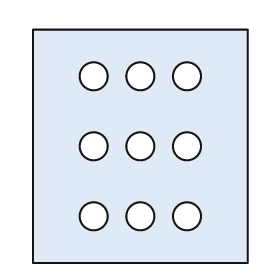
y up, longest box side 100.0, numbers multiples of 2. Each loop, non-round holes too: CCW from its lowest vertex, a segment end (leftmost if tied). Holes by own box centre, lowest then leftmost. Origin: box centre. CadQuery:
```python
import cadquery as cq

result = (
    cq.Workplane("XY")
    .moveTo(-46.0, -50.0)
    .lineTo(46.0, -50.0)
    .lineTo(46.0, 50.0)
    .lineTo(-46.0, 50.0)
    .close()
    .moveTo(-20.0, -30.0)
    .circle(6.0)
    .moveTo(0.0, -30.0)
    .circle(6.0)
    .moveTo(20.0, -30.0)
    .circle(6.0)
    .moveTo(-20.0, 0.0)
    .circle(6.0)
    .moveTo(0.0, 0.0)
    .circle(6.0)
    .moveTo(20.0, 0.0)
    .circle(6.0)
    .moveTo(-20.0, 30.0)
    .circle(6.0)
    .moveTo(0.0, 30.0)
    .circle(6.0)
    .moveTo(20.0, 30.0)
    .circle(6.0)
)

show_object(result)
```